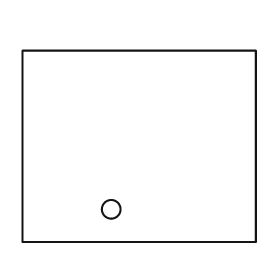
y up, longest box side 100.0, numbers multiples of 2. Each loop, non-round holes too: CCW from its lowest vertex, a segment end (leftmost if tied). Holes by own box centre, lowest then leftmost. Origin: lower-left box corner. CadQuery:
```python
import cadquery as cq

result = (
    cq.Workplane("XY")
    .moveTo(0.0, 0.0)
    .lineTo(100.0, 0.0)
    .lineTo(100.0, 82.0)
    .lineTo(0.0, 82.0)
    .close()
    .moveTo(38.0, 14.0)
    .circle(4.0)
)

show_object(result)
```